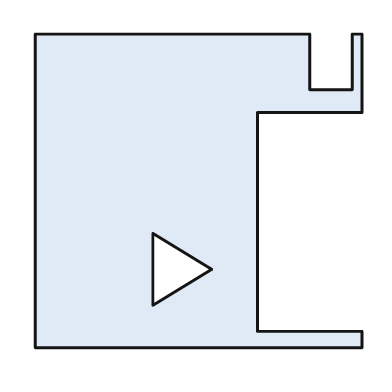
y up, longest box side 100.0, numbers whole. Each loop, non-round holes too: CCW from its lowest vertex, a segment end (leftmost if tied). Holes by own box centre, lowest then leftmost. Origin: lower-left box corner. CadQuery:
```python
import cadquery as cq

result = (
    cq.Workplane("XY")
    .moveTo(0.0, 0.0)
    .lineTo(100.0, 0.0)
    .lineTo(100.0, 5.0)
    .lineTo(68.0, 5.0)
    .lineTo(68.0, 72.0)
    .lineTo(100.0, 72.0)
    .lineTo(100.0, 96.0)
    .lineTo(97.0, 96.0)
    .lineTo(97.0, 79.0)
    .lineTo(84.0, 79.0)
    .lineTo(84.0, 96.0)
    .lineTo(0.0, 96.0)
    .close()
    .moveTo(36.0, 13.0)
    .lineTo(54.0, 24.0)
    .lineTo(36.0, 35.0)
    .close()
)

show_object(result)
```